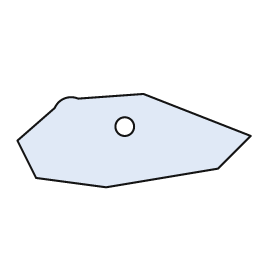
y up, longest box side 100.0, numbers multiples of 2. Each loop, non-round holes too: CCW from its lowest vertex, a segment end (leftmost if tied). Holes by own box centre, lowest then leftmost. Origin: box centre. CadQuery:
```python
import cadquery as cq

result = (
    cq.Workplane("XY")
    .moveTo(-12.0, -20.0)
    .lineTo(36.0, -12.0)
    .lineTo(50.0, 2.0)
    .lineTo(4.0, 20.0)
    .lineTo(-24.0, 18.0)
    .threePointArc((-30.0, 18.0), (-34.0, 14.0))
    .lineTo(-50.0, 0.0)
    .lineTo(-42.0, -16.0)
    .close()
    .moveTo(-4.0, 6.0)
    .circle(4.0)
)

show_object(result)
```